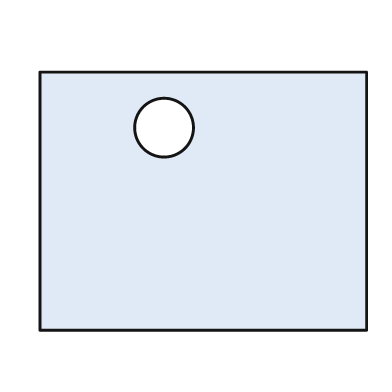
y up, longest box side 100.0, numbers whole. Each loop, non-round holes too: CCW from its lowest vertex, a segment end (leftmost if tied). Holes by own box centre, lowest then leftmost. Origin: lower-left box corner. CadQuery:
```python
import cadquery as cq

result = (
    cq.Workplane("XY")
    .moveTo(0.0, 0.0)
    .lineTo(100.0, 0.0)
    .lineTo(100.0, 79.0)
    .lineTo(0.0, 79.0)
    .close()
    .moveTo(38.0, 62.0)
    .circle(9.0)
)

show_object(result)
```